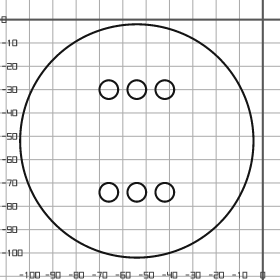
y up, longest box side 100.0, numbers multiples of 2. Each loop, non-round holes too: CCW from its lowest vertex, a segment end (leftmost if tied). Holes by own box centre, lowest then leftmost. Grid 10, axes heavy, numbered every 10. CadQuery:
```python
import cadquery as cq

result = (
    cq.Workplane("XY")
    .moveTo(-54.0, -52.0)
    .circle(50.0)
    .moveTo(-66.0, -74.0)
    .circle(4.0)
    .moveTo(-54.0, -74.0)
    .circle(4.0)
    .moveTo(-42.0, -74.0)
    .circle(4.0)
    .moveTo(-66.0, -30.0)
    .circle(4.0)
    .moveTo(-54.0, -30.0)
    .circle(4.0)
    .moveTo(-42.0, -30.0)
    .circle(4.0)
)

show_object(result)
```